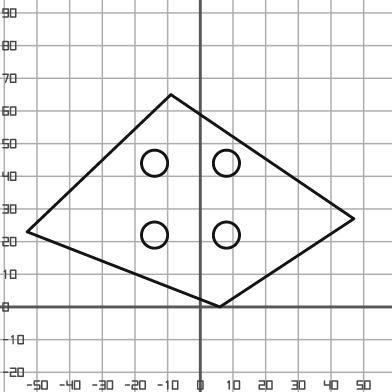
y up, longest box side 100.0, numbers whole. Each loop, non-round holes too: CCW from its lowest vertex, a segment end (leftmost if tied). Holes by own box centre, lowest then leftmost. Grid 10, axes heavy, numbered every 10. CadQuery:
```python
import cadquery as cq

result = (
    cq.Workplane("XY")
    .moveTo(6.0, 0.0)
    .lineTo(47.0, 27.0)
    .lineTo(-9.0, 65.0)
    .lineTo(-53.0, 23.0)
    .close()
    .moveTo(-14.0, 22.0)
    .circle(4.0)
    .moveTo(8.0, 22.0)
    .circle(4.0)
    .moveTo(-14.0, 44.0)
    .circle(4.0)
    .moveTo(8.0, 44.0)
    .circle(4.0)
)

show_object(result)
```